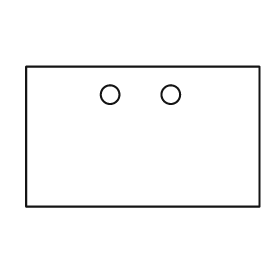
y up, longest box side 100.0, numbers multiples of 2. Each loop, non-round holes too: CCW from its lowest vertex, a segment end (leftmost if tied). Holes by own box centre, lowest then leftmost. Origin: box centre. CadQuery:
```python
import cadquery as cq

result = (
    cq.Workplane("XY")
    .moveTo(-50.0, -30.0)
    .lineTo(50.0, -30.0)
    .lineTo(50.0, 30.0)
    .lineTo(-50.0, 30.0)
    .close()
    .moveTo(-14.0, 18.0)
    .circle(4.0)
    .moveTo(12.0, 18.0)
    .circle(4.0)
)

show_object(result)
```